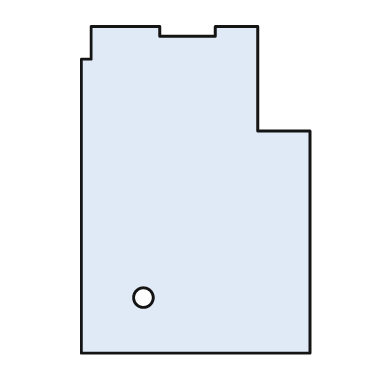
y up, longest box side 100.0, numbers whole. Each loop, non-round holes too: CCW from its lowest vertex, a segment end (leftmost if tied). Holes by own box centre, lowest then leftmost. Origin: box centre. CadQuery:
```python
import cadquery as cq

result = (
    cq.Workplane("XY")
    .moveTo(-35.0, -50.0)
    .lineTo(35.0, -50.0)
    .lineTo(35.0, 18.0)
    .lineTo(19.0, 18.0)
    .lineTo(19.0, 50.0)
    .lineTo(6.0, 50.0)
    .lineTo(6.0, 47.0)
    .lineTo(-11.0, 47.0)
    .lineTo(-11.0, 50.0)
    .lineTo(-32.0, 50.0)
    .lineTo(-32.0, 40.0)
    .lineTo(-35.0, 40.0)
    .close()
    .moveTo(-16.0, -33.0)
    .circle(3.0)
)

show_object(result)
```